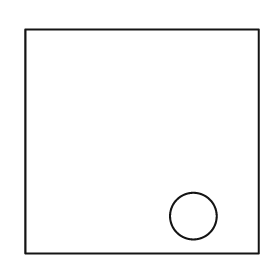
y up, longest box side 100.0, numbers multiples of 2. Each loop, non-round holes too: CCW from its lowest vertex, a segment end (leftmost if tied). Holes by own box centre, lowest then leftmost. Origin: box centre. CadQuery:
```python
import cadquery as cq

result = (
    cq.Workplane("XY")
    .moveTo(-50.0, -48.0)
    .lineTo(50.0, -48.0)
    .lineTo(50.0, 48.0)
    .lineTo(-50.0, 48.0)
    .close()
    .moveTo(22.0, -32.0)
    .circle(10.0)
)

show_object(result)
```